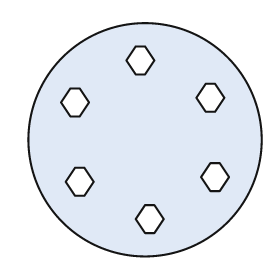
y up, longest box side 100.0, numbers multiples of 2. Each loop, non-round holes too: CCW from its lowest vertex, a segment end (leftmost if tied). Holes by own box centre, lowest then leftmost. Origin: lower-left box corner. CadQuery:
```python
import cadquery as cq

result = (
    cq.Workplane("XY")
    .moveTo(50.0, 50.0)
    .circle(50.0)
    .moveTo(50.0, 10.0)
    .lineTo(54.0, 10.0)
    .lineTo(58.0, 16.0)
    .lineTo(54.0, 22.0)
    .lineTo(50.0, 22.0)
    .lineTo(46.0, 16.0)
    .close()
    .moveTo(20.0, 26.0)
    .lineTo(24.0, 26.0)
    .lineTo(28.0, 32.0)
    .lineTo(24.0, 38.0)
    .lineTo(20.0, 38.0)
    .lineTo(16.0, 32.0)
    .close()
    .moveTo(78.0, 28.0)
    .lineTo(82.0, 28.0)
    .lineTo(86.0, 34.0)
    .lineTo(82.0, 40.0)
    .lineTo(78.0, 40.0)
    .lineTo(74.0, 34.0)
    .close()
    .moveTo(18.0, 60.0)
    .lineTo(22.0, 60.0)
    .lineTo(26.0, 66.0)
    .lineTo(22.0, 72.0)
    .lineTo(18.0, 72.0)
    .lineTo(14.0, 66.0)
    .close()
    .moveTo(76.0, 62.0)
    .lineTo(80.0, 62.0)
    .lineTo(84.0, 68.0)
    .lineTo(80.0, 74.0)
    .lineTo(76.0, 74.0)
    .lineTo(72.0, 68.0)
    .close()
    .moveTo(46.0, 78.0)
    .lineTo(50.0, 78.0)
    .lineTo(54.0, 84.0)
    .lineTo(50.0, 90.0)
    .lineTo(46.0, 90.0)
    .lineTo(42.0, 84.0)
    .close()
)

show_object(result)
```